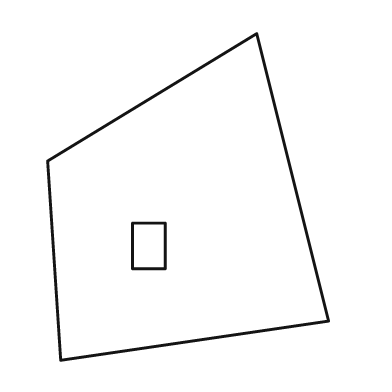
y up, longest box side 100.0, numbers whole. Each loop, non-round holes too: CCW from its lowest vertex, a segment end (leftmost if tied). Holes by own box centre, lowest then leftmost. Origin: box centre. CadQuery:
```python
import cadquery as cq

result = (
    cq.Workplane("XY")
    .moveTo(-39.0, -50.0)
    .lineTo(43.0, -38.0)
    .lineTo(21.0, 50.0)
    .lineTo(-43.0, 11.0)
    .close()
    .moveTo(-17.0, -22.0)
    .lineTo(-7.0, -22.0)
    .lineTo(-7.0, -8.0)
    .lineTo(-17.0, -8.0)
    .close()
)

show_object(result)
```